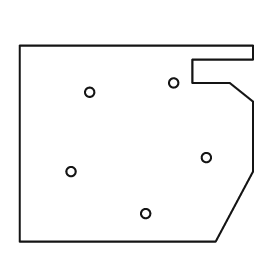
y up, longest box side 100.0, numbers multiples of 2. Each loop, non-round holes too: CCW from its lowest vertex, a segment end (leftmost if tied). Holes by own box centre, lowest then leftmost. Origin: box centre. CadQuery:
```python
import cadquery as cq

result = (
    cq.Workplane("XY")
    .moveTo(-50.0, -42.0)
    .lineTo(34.0, -42.0)
    .lineTo(50.0, -12.0)
    .lineTo(50.0, 18.0)
    .lineTo(40.0, 26.0)
    .lineTo(24.0, 26.0)
    .lineTo(24.0, 36.0)
    .lineTo(50.0, 36.0)
    .lineTo(50.0, 42.0)
    .lineTo(-50.0, 42.0)
    .close()
    .moveTo(4.0, -30.0)
    .circle(2.0)
    .moveTo(-28.0, -12.0)
    .circle(2.0)
    .moveTo(30.0, -6.0)
    .circle(2.0)
    .moveTo(-20.0, 22.0)
    .circle(2.0)
    .moveTo(16.0, 26.0)
    .circle(2.0)
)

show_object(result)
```